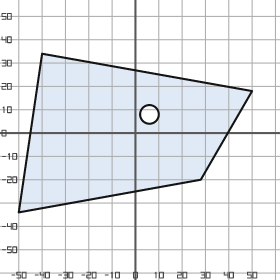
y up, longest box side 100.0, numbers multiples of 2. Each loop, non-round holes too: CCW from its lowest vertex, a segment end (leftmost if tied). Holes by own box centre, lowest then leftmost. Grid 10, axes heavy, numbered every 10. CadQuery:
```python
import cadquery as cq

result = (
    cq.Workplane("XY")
    .moveTo(-50.0, -34.0)
    .lineTo(28.0, -20.0)
    .lineTo(50.0, 18.0)
    .lineTo(-40.0, 34.0)
    .close()
    .moveTo(6.0, 8.0)
    .circle(4.0)
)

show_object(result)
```